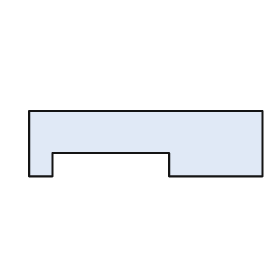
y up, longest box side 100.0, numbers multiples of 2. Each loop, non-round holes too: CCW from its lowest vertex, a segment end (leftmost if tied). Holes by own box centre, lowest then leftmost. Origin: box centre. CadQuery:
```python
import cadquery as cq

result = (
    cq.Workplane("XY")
    .moveTo(-50.0, -14.0)
    .lineTo(-40.0, -14.0)
    .lineTo(-40.0, -4.0)
    .lineTo(10.0, -4.0)
    .lineTo(10.0, -14.0)
    .lineTo(50.0, -14.0)
    .lineTo(50.0, 14.0)
    .lineTo(-50.0, 14.0)
    .close()
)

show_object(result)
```